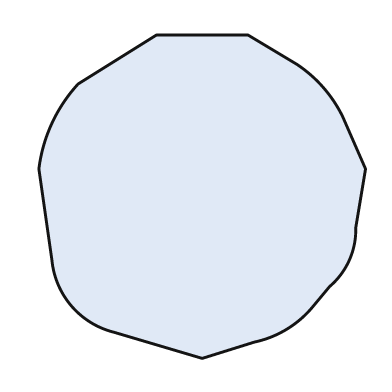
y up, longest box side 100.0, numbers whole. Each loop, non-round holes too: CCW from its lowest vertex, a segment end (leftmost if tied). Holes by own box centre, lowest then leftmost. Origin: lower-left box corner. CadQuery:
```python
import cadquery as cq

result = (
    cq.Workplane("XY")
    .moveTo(50.0, 0.0)
    .lineTo(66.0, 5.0)
    .threePointArc((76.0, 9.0), (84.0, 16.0))
    .lineTo(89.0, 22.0)
    .threePointArc((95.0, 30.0), (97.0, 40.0))
    .lineTo(100.0, 58.0)
    .lineTo(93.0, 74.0)
    .threePointArc((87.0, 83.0), (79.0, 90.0))
    .lineTo(64.0, 99.0)
    .lineTo(36.0, 99.0)
    .lineTo(12.0, 84.0)
    .threePointArc((4.0, 72.0), (0.0, 58.0))
    .lineTo(4.0, 30.0)
    .threePointArc((10.0, 16.0), (23.0, 8.0))
    .close()
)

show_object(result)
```